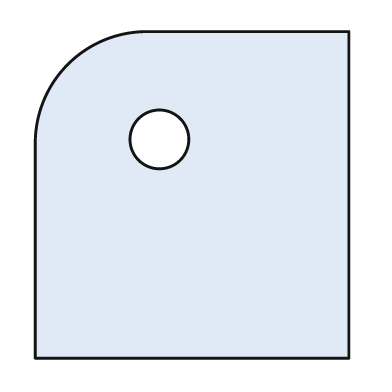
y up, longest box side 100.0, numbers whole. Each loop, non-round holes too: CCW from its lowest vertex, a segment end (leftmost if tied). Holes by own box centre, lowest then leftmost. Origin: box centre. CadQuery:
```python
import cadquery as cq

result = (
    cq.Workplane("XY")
    .moveTo(-48.0, -50.0)
    .lineTo(48.0, -50.0)
    .lineTo(48.0, 50.0)
    .lineTo(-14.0, 50.0)
    .threePointArc((-38.0, 40.0), (-48.0, 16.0))
    .close()
    .moveTo(-10.0, 17.0)
    .circle(9.0)
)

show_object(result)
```